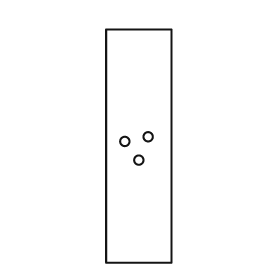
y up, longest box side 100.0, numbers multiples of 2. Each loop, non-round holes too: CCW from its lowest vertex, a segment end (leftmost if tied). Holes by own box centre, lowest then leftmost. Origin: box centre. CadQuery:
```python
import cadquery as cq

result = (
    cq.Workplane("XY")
    .moveTo(-14.0, -50.0)
    .lineTo(14.0, -50.0)
    .lineTo(14.0, 50.0)
    .lineTo(-14.0, 50.0)
    .close()
    .moveTo(0.0, -6.0)
    .circle(2.0)
    .moveTo(-6.0, 2.0)
    .circle(2.0)
    .moveTo(4.0, 4.0)
    .circle(2.0)
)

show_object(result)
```